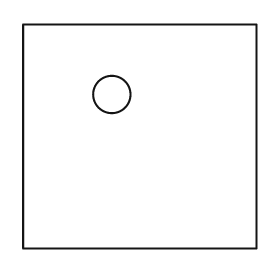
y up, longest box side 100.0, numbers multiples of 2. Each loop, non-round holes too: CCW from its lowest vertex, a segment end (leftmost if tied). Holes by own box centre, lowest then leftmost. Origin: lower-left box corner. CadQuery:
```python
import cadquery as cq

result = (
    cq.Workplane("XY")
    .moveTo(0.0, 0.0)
    .lineTo(100.0, 0.0)
    .lineTo(100.0, 96.0)
    .lineTo(0.0, 96.0)
    .close()
    .moveTo(38.0, 66.0)
    .circle(8.0)
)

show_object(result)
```